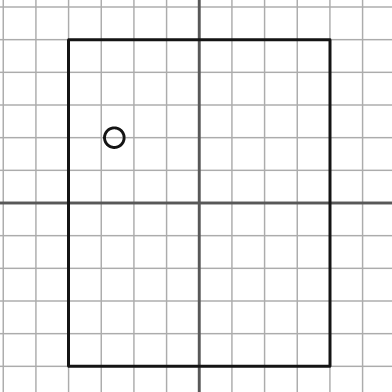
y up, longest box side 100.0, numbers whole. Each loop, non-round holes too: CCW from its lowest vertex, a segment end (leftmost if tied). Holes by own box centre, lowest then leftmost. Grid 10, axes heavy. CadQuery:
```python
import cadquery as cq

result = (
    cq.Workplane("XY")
    .moveTo(-40.0, -50.0)
    .lineTo(40.0, -50.0)
    .lineTo(40.0, 50.0)
    .lineTo(-40.0, 50.0)
    .close()
    .moveTo(-26.0, 20.0)
    .circle(3.0)
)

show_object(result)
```